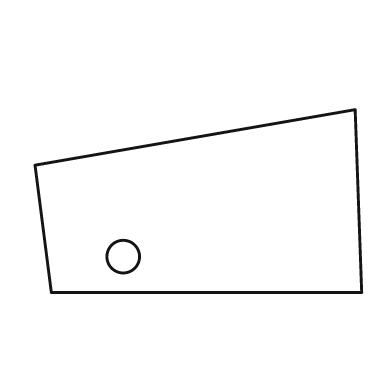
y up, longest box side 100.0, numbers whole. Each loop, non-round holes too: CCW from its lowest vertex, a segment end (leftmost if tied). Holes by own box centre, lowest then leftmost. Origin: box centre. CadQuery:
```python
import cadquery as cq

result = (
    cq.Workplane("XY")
    .moveTo(-45.0, -28.0)
    .lineTo(50.0, -28.0)
    .lineTo(48.0, 28.0)
    .lineTo(-50.0, 11.0)
    .close()
    .moveTo(-23.0, -17.0)
    .circle(5.0)
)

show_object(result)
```